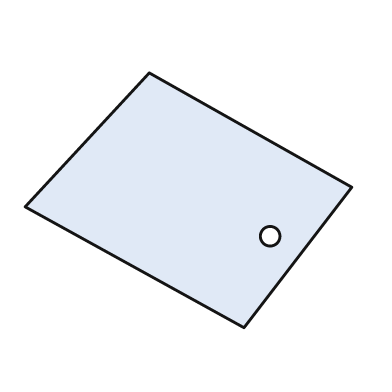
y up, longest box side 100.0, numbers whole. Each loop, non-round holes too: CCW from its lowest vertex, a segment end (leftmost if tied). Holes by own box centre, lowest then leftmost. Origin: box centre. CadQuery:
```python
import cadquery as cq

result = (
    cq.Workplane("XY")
    .moveTo(17.0, -39.0)
    .lineTo(50.0, 4.0)
    .lineTo(-12.0, 39.0)
    .lineTo(-50.0, -2.0)
    .close()
    .moveTo(25.0, -11.0)
    .circle(3.0)
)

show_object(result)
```